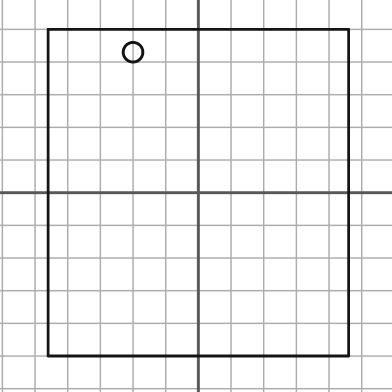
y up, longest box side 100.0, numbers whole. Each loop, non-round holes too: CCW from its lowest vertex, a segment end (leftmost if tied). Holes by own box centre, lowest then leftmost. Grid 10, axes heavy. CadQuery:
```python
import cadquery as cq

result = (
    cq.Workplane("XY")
    .moveTo(-46.0, -50.0)
    .lineTo(46.0, -50.0)
    .lineTo(46.0, 50.0)
    .lineTo(-46.0, 50.0)
    .close()
    .moveTo(-20.0, 43.0)
    .circle(3.0)
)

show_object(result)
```